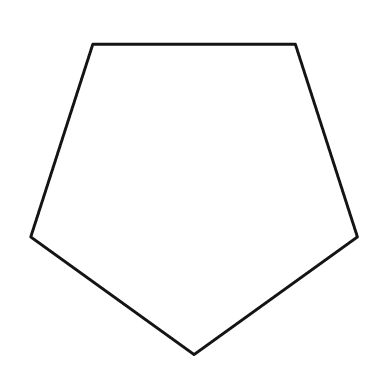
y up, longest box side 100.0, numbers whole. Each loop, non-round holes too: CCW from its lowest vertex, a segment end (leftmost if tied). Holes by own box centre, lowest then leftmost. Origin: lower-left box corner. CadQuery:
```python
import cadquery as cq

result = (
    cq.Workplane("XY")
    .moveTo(50.0, 0.0)
    .lineTo(100.0, 36.0)
    .lineTo(81.0, 95.0)
    .lineTo(19.0, 95.0)
    .lineTo(0.0, 36.0)
    .close()
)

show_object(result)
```